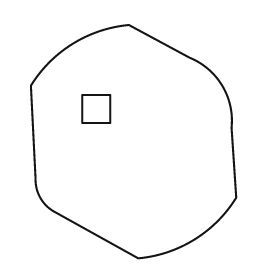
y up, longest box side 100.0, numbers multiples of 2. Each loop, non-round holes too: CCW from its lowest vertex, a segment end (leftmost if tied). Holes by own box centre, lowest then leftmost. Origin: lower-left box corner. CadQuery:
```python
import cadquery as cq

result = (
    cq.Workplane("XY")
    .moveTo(46.0, 0.0)
    .threePointArc((70.0, 8.0), (88.0, 26.0))
    .lineTo(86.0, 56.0)
    .threePointArc((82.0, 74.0), (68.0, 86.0))
    .lineTo(42.0, 100.0)
    .threePointArc((18.0, 92.0), (0.0, 74.0))
    .lineTo(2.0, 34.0)
    .threePointArc((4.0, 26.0), (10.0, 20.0))
    .close()
    .moveTo(22.0, 58.0)
    .lineTo(34.0, 58.0)
    .lineTo(34.0, 70.0)
    .lineTo(22.0, 70.0)
    .close()
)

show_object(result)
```